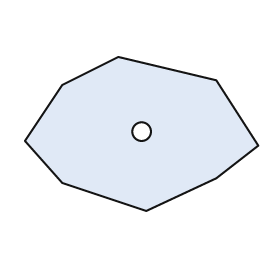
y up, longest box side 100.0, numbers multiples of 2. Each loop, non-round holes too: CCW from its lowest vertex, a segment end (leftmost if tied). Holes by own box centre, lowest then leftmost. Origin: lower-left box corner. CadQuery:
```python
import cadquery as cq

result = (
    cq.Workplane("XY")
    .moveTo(52.0, 0.0)
    .lineTo(82.0, 14.0)
    .lineTo(100.0, 28.0)
    .lineTo(82.0, 56.0)
    .lineTo(40.0, 66.0)
    .lineTo(16.0, 54.0)
    .lineTo(0.0, 30.0)
    .lineTo(16.0, 12.0)
    .close()
    .moveTo(50.0, 34.0)
    .circle(4.0)
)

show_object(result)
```